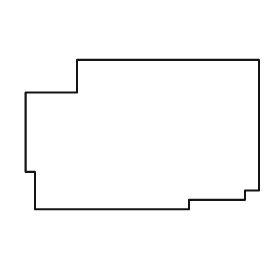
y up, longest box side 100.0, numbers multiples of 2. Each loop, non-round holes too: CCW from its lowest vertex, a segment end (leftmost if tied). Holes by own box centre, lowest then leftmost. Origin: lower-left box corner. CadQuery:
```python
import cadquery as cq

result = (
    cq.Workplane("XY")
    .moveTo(4.0, 0.0)
    .lineTo(70.0, 0.0)
    .lineTo(70.0, 4.0)
    .lineTo(94.0, 4.0)
    .lineTo(94.0, 8.0)
    .lineTo(100.0, 8.0)
    .lineTo(100.0, 64.0)
    .lineTo(22.0, 64.0)
    .lineTo(22.0, 50.0)
    .lineTo(0.0, 50.0)
    .lineTo(0.0, 16.0)
    .lineTo(4.0, 16.0)
    .close()
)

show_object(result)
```